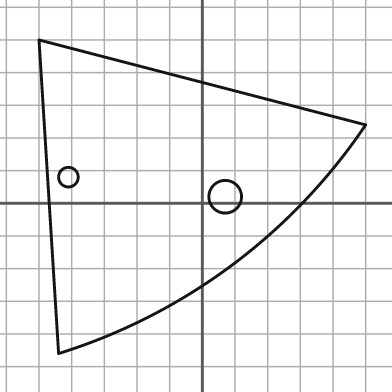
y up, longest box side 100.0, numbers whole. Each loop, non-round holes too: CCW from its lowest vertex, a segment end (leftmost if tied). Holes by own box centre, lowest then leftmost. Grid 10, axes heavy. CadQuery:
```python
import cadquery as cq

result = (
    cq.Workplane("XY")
    .moveTo(-44.0, -46.0)
    .threePointArc((9.0, -19.0), (50.0, 24.0))
    .lineTo(-50.0, 50.0)
    .close()
    .moveTo(7.0, 2.0)
    .circle(5.0)
    .moveTo(-41.0, 8.0)
    .circle(3.0)
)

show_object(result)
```